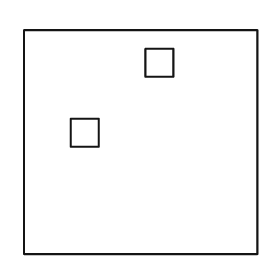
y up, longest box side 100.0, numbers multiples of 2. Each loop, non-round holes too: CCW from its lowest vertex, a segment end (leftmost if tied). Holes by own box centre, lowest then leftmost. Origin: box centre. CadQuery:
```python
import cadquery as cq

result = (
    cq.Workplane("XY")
    .moveTo(-50.0, -48.0)
    .lineTo(50.0, -48.0)
    .lineTo(50.0, 48.0)
    .lineTo(-50.0, 48.0)
    .close()
    .moveTo(-30.0, -2.0)
    .lineTo(-18.0, -2.0)
    .lineTo(-18.0, 10.0)
    .lineTo(-30.0, 10.0)
    .close()
    .moveTo(2.0, 28.0)
    .lineTo(14.0, 28.0)
    .lineTo(14.0, 40.0)
    .lineTo(2.0, 40.0)
    .close()
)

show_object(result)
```